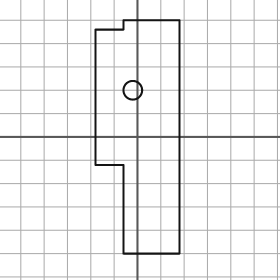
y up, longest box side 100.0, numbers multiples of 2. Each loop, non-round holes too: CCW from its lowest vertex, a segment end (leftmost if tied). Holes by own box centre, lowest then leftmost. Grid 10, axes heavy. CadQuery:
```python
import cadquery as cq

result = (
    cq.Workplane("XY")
    .moveTo(-6.0, -50.0)
    .lineTo(18.0, -50.0)
    .lineTo(18.0, 50.0)
    .lineTo(-6.0, 50.0)
    .lineTo(-6.0, 46.0)
    .lineTo(-18.0, 46.0)
    .lineTo(-18.0, -12.0)
    .lineTo(-6.0, -12.0)
    .close()
    .moveTo(-2.0, 20.0)
    .circle(4.0)
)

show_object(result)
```